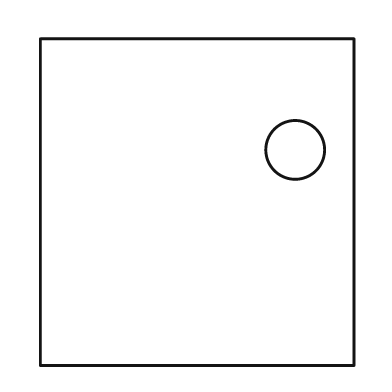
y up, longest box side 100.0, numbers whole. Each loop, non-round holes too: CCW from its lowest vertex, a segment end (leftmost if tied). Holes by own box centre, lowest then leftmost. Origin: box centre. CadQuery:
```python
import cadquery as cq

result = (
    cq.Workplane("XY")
    .moveTo(-48.0, -50.0)
    .lineTo(48.0, -50.0)
    .lineTo(48.0, 50.0)
    .lineTo(-48.0, 50.0)
    .close()
    .moveTo(30.0, 16.0)
    .circle(9.0)
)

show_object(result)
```